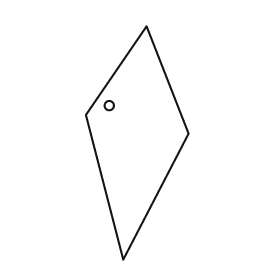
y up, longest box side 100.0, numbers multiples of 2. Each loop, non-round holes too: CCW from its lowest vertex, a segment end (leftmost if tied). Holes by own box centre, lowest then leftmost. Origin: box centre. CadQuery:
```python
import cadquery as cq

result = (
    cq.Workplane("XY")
    .moveTo(-6.0, -50.0)
    .lineTo(22.0, 4.0)
    .lineTo(4.0, 50.0)
    .lineTo(-22.0, 12.0)
    .close()
    .moveTo(-12.0, 16.0)
    .circle(2.0)
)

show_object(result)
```